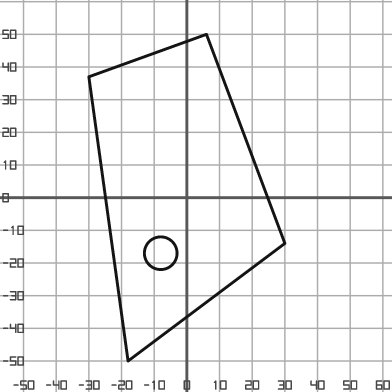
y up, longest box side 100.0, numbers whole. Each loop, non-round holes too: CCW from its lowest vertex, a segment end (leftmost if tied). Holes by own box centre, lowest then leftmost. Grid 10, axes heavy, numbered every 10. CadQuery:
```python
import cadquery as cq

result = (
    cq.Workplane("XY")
    .moveTo(-18.0, -50.0)
    .lineTo(30.0, -14.0)
    .lineTo(6.0, 50.0)
    .lineTo(-30.0, 37.0)
    .close()
    .moveTo(-8.0, -17.0)
    .circle(5.0)
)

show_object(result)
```